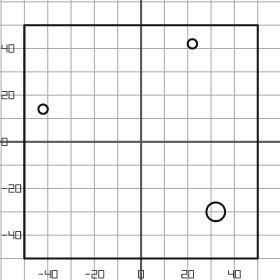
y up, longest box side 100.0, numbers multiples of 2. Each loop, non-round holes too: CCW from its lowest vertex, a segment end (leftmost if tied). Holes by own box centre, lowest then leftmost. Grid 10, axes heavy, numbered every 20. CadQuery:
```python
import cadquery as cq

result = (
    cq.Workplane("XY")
    .moveTo(-50.0, -50.0)
    .lineTo(50.0, -50.0)
    .lineTo(50.0, 50.0)
    .lineTo(-50.0, 50.0)
    .close()
    .moveTo(32.0, -30.0)
    .circle(4.0)
    .moveTo(-42.0, 14.0)
    .circle(2.0)
    .moveTo(22.0, 42.0)
    .circle(2.0)
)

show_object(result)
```